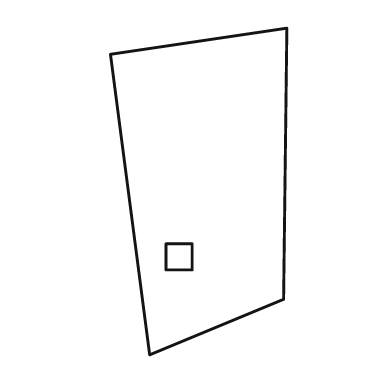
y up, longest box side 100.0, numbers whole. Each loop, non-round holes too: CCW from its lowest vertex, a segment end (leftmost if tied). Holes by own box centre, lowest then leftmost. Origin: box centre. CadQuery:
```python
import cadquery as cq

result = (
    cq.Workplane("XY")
    .moveTo(-15.0, -50.0)
    .lineTo(26.0, -33.0)
    .lineTo(27.0, 50.0)
    .lineTo(-27.0, 42.0)
    .close()
    .moveTo(-10.0, -24.0)
    .lineTo(-2.0, -24.0)
    .lineTo(-2.0, -16.0)
    .lineTo(-10.0, -16.0)
    .close()
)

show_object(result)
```